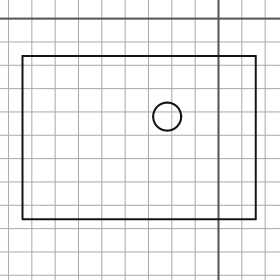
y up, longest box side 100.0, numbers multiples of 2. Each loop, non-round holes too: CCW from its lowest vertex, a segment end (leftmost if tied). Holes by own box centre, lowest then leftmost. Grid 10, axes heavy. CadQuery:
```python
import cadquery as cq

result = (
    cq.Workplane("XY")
    .moveTo(-84.0, -86.0)
    .lineTo(16.0, -86.0)
    .lineTo(16.0, -16.0)
    .lineTo(-84.0, -16.0)
    .close()
    .moveTo(-22.0, -42.0)
    .circle(6.0)
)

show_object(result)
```